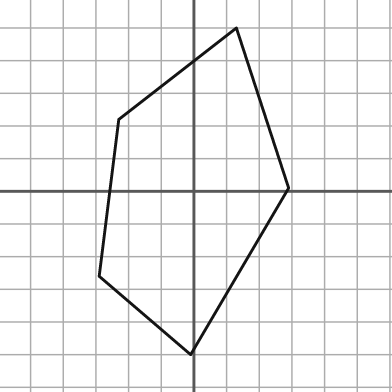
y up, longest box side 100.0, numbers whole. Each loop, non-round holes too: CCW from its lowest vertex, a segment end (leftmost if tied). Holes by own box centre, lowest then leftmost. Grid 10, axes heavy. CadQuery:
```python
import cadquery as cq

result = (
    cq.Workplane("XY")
    .moveTo(-1.0, -50.0)
    .lineTo(29.0, 1.0)
    .lineTo(13.0, 50.0)
    .lineTo(-23.0, 22.0)
    .lineTo(-29.0, -26.0)
    .close()
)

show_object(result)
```